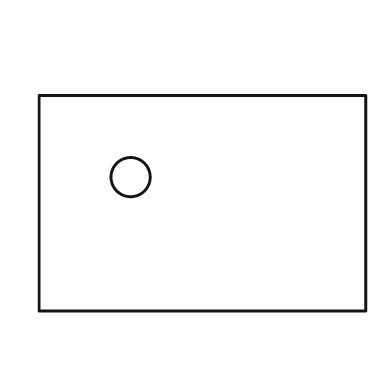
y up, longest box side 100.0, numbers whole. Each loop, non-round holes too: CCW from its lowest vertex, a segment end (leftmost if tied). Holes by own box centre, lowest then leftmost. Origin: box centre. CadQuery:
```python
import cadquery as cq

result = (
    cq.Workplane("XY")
    .moveTo(-50.0, -33.0)
    .lineTo(50.0, -33.0)
    .lineTo(50.0, 33.0)
    .lineTo(-50.0, 33.0)
    .close()
    .moveTo(-22.0, 8.0)
    .circle(6.0)
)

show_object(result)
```